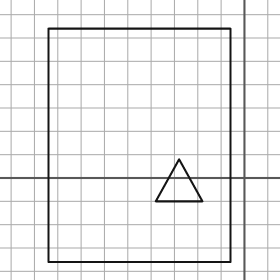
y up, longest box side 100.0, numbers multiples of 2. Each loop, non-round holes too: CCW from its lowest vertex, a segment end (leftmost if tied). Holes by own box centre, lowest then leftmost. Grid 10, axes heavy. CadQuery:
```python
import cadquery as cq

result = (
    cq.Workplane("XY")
    .moveTo(-84.0, -36.0)
    .lineTo(-6.0, -36.0)
    .lineTo(-6.0, 64.0)
    .lineTo(-84.0, 64.0)
    .close()
    .moveTo(-38.0, -10.0)
    .lineTo(-18.0, -10.0)
    .lineTo(-28.0, 8.0)
    .close()
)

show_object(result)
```